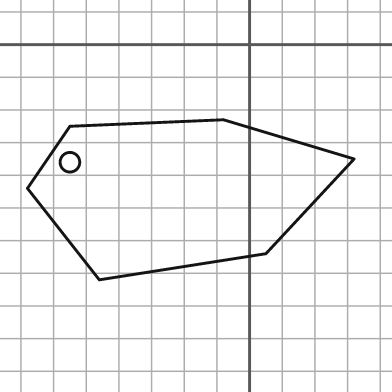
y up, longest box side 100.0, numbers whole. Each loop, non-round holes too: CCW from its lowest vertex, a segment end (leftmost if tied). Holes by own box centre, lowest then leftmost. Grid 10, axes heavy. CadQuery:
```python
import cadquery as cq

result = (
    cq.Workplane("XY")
    .moveTo(-46.0, -72.0)
    .lineTo(5.0, -64.0)
    .lineTo(32.0, -35.0)
    .lineTo(-8.0, -23.0)
    .lineTo(-55.0, -25.0)
    .lineTo(-68.0, -44.0)
    .close()
    .moveTo(-55.0, -36.0)
    .circle(3.0)
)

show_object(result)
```